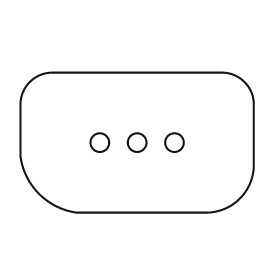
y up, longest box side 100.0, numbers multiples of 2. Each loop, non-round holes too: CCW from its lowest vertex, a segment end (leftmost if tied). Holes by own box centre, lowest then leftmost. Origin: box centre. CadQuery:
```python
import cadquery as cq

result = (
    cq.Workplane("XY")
    .moveTo(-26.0, -30.0)
    .lineTo(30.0, -30.0)
    .threePointArc((44.0, -24.0), (50.0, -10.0))
    .lineTo(50.0, 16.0)
    .threePointArc((46.0, 26.0), (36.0, 30.0))
    .lineTo(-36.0, 30.0)
    .threePointArc((-46.0, 26.0), (-50.0, 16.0))
    .lineTo(-50.0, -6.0)
    .threePointArc((-42.0, -22.0), (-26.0, -30.0))
    .close()
    .moveTo(-16.0, 0.0)
    .circle(4.0)
    .moveTo(0.0, 0.0)
    .circle(4.0)
    .moveTo(16.0, 0.0)
    .circle(4.0)
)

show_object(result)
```